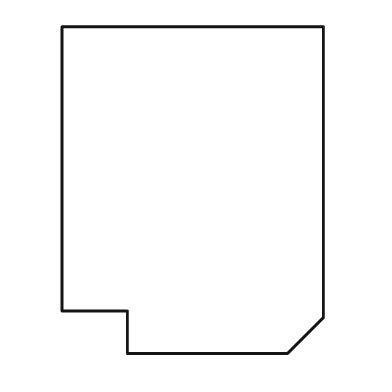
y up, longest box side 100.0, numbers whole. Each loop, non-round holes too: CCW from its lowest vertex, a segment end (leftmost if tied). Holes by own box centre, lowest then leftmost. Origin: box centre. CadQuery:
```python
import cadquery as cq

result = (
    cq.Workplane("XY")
    .moveTo(-20.0, -50.0)
    .lineTo(29.0, -50.0)
    .lineTo(40.0, -39.0)
    .lineTo(40.0, 50.0)
    .lineTo(-40.0, 50.0)
    .lineTo(-40.0, -37.0)
    .lineTo(-20.0, -37.0)
    .close()
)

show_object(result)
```